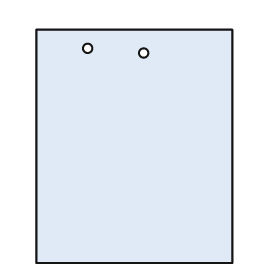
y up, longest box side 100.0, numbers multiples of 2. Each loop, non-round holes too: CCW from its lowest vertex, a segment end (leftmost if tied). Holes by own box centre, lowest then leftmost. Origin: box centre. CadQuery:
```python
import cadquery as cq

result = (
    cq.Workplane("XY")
    .moveTo(-42.0, -50.0)
    .lineTo(42.0, -50.0)
    .lineTo(42.0, 50.0)
    .lineTo(-42.0, 50.0)
    .close()
    .moveTo(4.0, 40.0)
    .circle(2.0)
    .moveTo(-20.0, 42.0)
    .circle(2.0)
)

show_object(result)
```